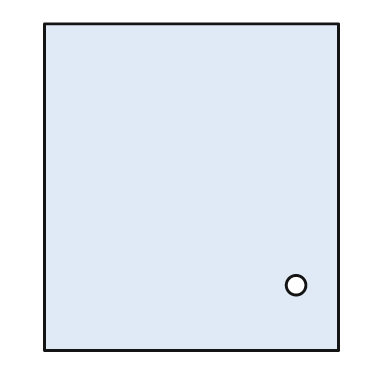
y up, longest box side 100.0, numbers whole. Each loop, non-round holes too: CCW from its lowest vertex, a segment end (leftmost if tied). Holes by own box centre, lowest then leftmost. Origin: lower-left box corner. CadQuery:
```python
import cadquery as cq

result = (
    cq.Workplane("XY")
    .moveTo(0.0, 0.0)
    .lineTo(90.0, 0.0)
    .lineTo(90.0, 100.0)
    .lineTo(0.0, 100.0)
    .close()
    .moveTo(77.0, 20.0)
    .circle(3.0)
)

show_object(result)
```